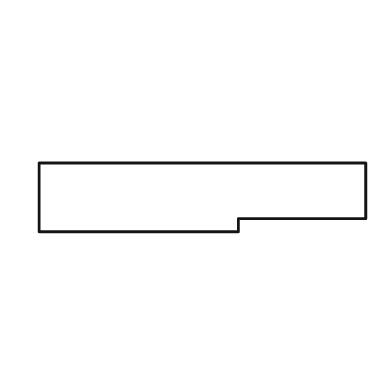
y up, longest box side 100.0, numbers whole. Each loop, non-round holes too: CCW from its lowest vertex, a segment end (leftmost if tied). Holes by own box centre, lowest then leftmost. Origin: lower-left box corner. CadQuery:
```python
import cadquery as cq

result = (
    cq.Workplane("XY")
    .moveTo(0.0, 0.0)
    .lineTo(61.0, 0.0)
    .lineTo(61.0, 4.0)
    .lineTo(100.0, 4.0)
    .lineTo(100.0, 21.0)
    .lineTo(0.0, 21.0)
    .close()
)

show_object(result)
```